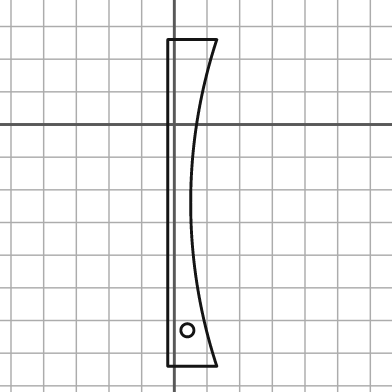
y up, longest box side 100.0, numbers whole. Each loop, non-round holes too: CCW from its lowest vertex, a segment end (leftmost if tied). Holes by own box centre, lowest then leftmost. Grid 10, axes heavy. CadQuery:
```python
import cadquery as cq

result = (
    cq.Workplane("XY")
    .moveTo(-2.0, -74.0)
    .lineTo(13.0, -74.0)
    .threePointArc((5.0, -24.0), (13.0, 26.0))
    .lineTo(-2.0, 26.0)
    .close()
    .moveTo(4.0, -63.0)
    .circle(2.0)
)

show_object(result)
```